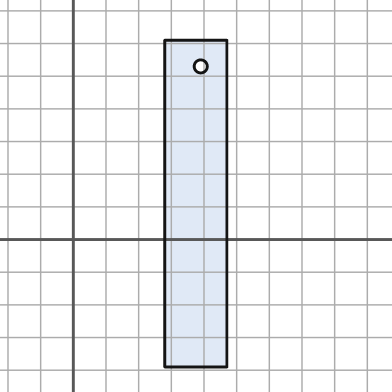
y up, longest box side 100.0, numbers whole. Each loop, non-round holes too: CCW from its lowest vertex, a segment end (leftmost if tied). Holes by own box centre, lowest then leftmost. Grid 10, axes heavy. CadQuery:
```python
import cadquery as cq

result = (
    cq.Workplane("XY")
    .moveTo(28.0, -39.0)
    .lineTo(47.0, -39.0)
    .lineTo(47.0, 61.0)
    .lineTo(28.0, 61.0)
    .close()
    .moveTo(39.0, 53.0)
    .circle(2.0)
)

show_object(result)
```